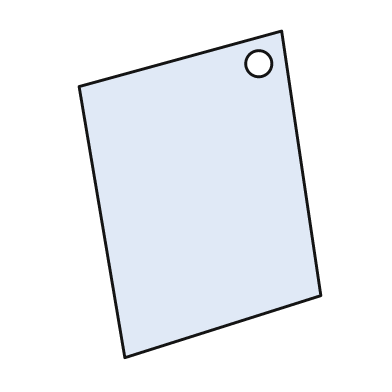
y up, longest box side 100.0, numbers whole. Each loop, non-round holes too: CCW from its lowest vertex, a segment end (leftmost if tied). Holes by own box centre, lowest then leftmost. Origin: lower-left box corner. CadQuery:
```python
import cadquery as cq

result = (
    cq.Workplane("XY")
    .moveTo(14.0, 0.0)
    .lineTo(74.0, 19.0)
    .lineTo(62.0, 100.0)
    .lineTo(0.0, 83.0)
    .close()
    .moveTo(55.0, 90.0)
    .circle(4.0)
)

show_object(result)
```